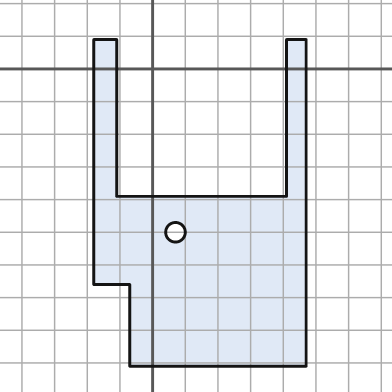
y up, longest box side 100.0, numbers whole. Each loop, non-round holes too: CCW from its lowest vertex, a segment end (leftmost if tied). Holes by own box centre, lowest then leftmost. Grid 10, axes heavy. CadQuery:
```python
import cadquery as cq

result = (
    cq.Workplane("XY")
    .moveTo(-7.0, -91.0)
    .lineTo(47.0, -91.0)
    .lineTo(47.0, 9.0)
    .lineTo(41.0, 9.0)
    .lineTo(41.0, -39.0)
    .lineTo(-11.0, -39.0)
    .lineTo(-11.0, 9.0)
    .lineTo(-18.0, 9.0)
    .lineTo(-18.0, -66.0)
    .lineTo(-7.0, -66.0)
    .close()
    .moveTo(7.0, -50.0)
    .circle(3.0)
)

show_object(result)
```